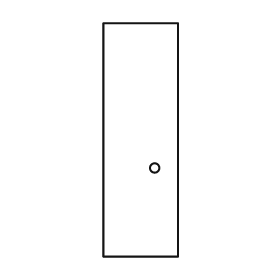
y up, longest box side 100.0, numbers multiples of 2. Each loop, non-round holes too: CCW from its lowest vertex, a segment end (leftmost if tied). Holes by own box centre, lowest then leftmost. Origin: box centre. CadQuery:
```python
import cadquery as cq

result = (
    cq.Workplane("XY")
    .moveTo(-16.0, -50.0)
    .lineTo(16.0, -50.0)
    .lineTo(16.0, 50.0)
    .lineTo(-16.0, 50.0)
    .close()
    .moveTo(6.0, -12.0)
    .circle(2.0)
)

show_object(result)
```